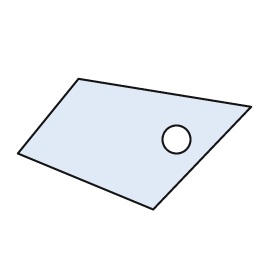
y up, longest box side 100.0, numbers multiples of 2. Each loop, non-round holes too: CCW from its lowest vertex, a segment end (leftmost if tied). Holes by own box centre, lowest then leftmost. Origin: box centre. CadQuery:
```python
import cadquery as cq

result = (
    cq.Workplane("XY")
    .moveTo(8.0, -28.0)
    .lineTo(50.0, 16.0)
    .lineTo(-24.0, 28.0)
    .lineTo(-50.0, -4.0)
    .close()
    .moveTo(18.0, 2.0)
    .circle(6.0)
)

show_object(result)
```